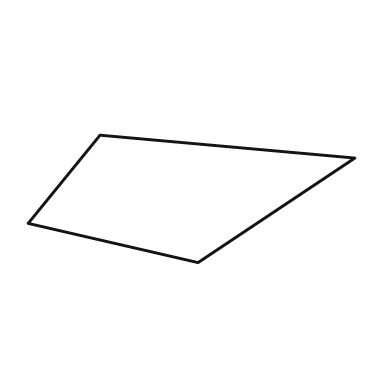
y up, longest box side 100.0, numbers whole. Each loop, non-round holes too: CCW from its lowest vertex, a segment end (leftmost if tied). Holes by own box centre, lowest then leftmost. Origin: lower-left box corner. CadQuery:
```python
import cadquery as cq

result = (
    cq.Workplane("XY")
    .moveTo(52.0, 0.0)
    .lineTo(100.0, 32.0)
    .lineTo(22.0, 39.0)
    .lineTo(0.0, 12.0)
    .close()
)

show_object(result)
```